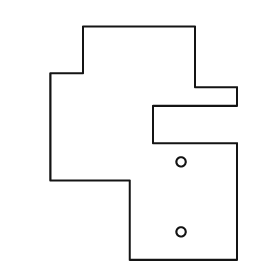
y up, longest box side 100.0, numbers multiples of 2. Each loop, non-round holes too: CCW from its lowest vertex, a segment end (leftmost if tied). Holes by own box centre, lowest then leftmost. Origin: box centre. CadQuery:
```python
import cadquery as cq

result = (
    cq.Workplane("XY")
    .moveTo(-6.0, -50.0)
    .lineTo(40.0, -50.0)
    .lineTo(40.0, 0.0)
    .lineTo(4.0, 0.0)
    .lineTo(4.0, 16.0)
    .lineTo(40.0, 16.0)
    .lineTo(40.0, 24.0)
    .lineTo(22.0, 24.0)
    .lineTo(22.0, 50.0)
    .lineTo(-26.0, 50.0)
    .lineTo(-26.0, 30.0)
    .lineTo(-40.0, 30.0)
    .lineTo(-40.0, -16.0)
    .lineTo(-6.0, -16.0)
    .close()
    .moveTo(16.0, -38.0)
    .circle(2.0)
    .moveTo(16.0, -8.0)
    .circle(2.0)
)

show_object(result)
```